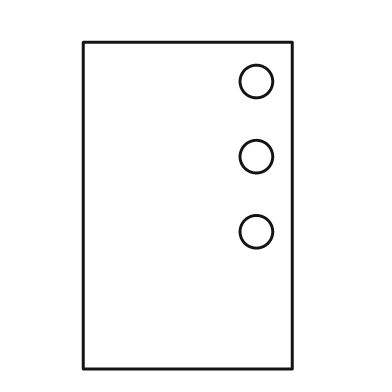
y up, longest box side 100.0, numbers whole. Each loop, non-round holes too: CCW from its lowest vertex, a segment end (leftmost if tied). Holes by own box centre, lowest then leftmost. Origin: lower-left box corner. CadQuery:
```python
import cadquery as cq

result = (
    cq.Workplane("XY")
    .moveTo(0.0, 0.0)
    .lineTo(64.0, 0.0)
    .lineTo(64.0, 100.0)
    .lineTo(0.0, 100.0)
    .close()
    .moveTo(53.0, 42.0)
    .circle(5.0)
    .moveTo(53.0, 65.0)
    .circle(5.0)
    .moveTo(53.0, 88.0)
    .circle(5.0)
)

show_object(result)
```